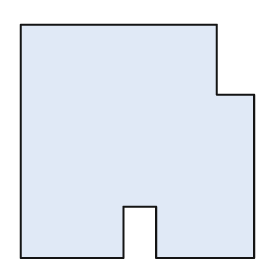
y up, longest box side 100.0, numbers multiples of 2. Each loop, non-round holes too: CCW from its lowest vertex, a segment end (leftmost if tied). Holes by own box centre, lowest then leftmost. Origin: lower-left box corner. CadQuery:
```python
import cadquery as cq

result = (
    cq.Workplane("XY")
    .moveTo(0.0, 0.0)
    .lineTo(44.0, 0.0)
    .lineTo(44.0, 22.0)
    .lineTo(58.0, 22.0)
    .lineTo(58.0, 0.0)
    .lineTo(100.0, 0.0)
    .lineTo(100.0, 70.0)
    .lineTo(84.0, 70.0)
    .lineTo(84.0, 100.0)
    .lineTo(0.0, 100.0)
    .close()
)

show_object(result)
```